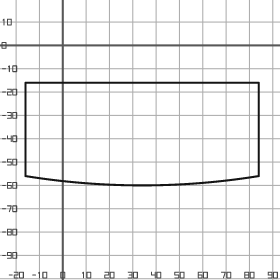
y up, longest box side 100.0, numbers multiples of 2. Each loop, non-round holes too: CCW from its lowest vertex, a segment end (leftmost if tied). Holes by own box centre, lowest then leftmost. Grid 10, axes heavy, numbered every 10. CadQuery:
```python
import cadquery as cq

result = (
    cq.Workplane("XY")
    .moveTo(-16.0, -56.0)
    .threePointArc((34.0, -60.0), (84.0, -56.0))
    .lineTo(84.0, -16.0)
    .lineTo(-16.0, -16.0)
    .close()
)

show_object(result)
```